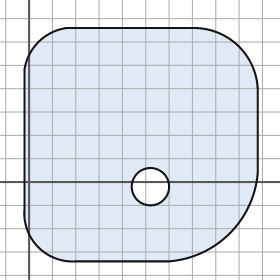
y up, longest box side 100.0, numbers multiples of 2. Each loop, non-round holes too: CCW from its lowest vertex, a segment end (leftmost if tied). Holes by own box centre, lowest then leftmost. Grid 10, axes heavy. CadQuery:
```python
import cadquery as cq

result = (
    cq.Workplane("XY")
    .moveTo(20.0, -34.0)
    .lineTo(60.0, -34.0)
    .threePointArc((86.0, -22.0), (98.0, 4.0))
    .lineTo(98.0, 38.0)
    .threePointArc((90.0, 58.0), (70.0, 66.0))
    .lineTo(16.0, 66.0)
    .threePointArc((4.0, 60.0), (-2.0, 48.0))
    .lineTo(-2.0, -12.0)
    .threePointArc((4.0, -28.0), (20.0, -34.0))
    .close()
    .moveTo(52.0, -2.0)
    .circle(8.0)
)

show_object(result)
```